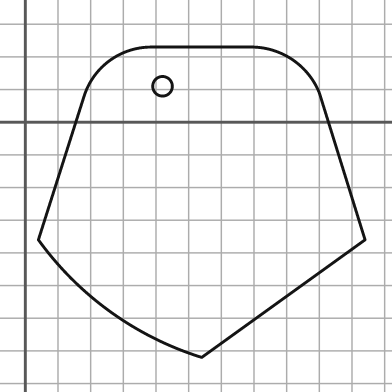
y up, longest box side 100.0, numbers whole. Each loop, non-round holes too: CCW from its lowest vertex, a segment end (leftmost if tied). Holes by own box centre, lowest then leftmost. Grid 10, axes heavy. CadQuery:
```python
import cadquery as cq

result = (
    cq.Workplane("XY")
    .moveTo(54.0, -72.0)
    .lineTo(104.0, -36.0)
    .lineTo(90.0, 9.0)
    .threePointArc((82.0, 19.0), (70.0, 23.0))
    .lineTo(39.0, 23.0)
    .threePointArc((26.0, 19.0), (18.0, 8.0))
    .lineTo(4.0, -36.0)
    .threePointArc((26.0, -58.0), (54.0, -72.0))
    .close()
    .moveTo(42.0, 11.0)
    .circle(3.0)
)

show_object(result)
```